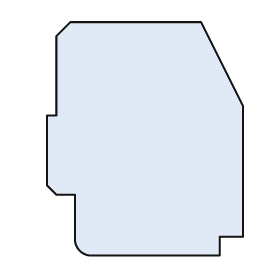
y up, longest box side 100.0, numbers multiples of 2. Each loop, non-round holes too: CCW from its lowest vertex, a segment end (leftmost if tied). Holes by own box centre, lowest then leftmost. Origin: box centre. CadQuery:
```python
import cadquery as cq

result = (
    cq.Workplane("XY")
    .moveTo(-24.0, -50.0)
    .lineTo(32.0, -50.0)
    .lineTo(32.0, -42.0)
    .lineTo(42.0, -42.0)
    .lineTo(42.0, 14.0)
    .lineTo(24.0, 50.0)
    .lineTo(-32.0, 50.0)
    .lineTo(-38.0, 44.0)
    .lineTo(-38.0, 10.0)
    .lineTo(-42.0, 10.0)
    .lineTo(-42.0, -20.0)
    .lineTo(-38.0, -24.0)
    .lineTo(-30.0, -24.0)
    .lineTo(-30.0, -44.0)
    .threePointArc((-28.0, -48.0), (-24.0, -50.0))
    .close()
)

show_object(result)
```